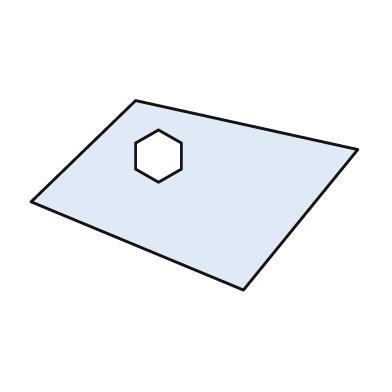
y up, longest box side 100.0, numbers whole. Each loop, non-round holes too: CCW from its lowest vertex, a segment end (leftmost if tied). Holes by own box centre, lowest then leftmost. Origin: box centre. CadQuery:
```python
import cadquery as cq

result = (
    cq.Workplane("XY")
    .moveTo(15.0, -29.0)
    .lineTo(50.0, 14.0)
    .lineTo(-18.0, 29.0)
    .lineTo(-50.0, -2.0)
    .close()
    .moveTo(-11.0, 4.0)
    .lineTo(-4.0, 8.0)
    .lineTo(-4.0, 16.0)
    .lineTo(-11.0, 20.0)
    .lineTo(-18.0, 16.0)
    .lineTo(-18.0, 8.0)
    .close()
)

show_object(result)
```